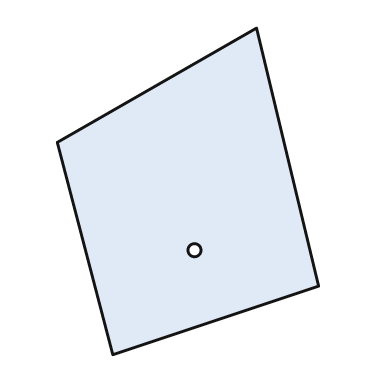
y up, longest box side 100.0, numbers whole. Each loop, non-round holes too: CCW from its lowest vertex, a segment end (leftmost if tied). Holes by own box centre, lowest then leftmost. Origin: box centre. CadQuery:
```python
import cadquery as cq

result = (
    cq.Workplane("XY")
    .moveTo(-23.0, -50.0)
    .lineTo(40.0, -29.0)
    .lineTo(21.0, 50.0)
    .lineTo(-40.0, 15.0)
    .close()
    .moveTo(2.0, -18.0)
    .circle(2.0)
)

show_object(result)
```